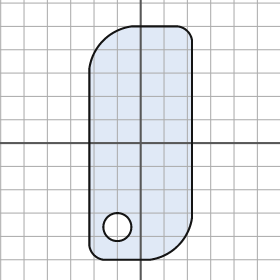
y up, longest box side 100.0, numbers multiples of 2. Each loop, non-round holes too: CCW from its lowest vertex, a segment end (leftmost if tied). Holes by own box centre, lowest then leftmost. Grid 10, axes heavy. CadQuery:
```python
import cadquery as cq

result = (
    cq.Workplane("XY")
    .moveTo(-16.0, -50.0)
    .lineTo(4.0, -50.0)
    .threePointArc((16.0, -44.0), (22.0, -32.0))
    .lineTo(22.0, 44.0)
    .threePointArc((20.0, 48.0), (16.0, 50.0))
    .lineTo(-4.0, 50.0)
    .threePointArc((-16.0, 44.0), (-22.0, 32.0))
    .lineTo(-22.0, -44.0)
    .threePointArc((-20.0, -48.0), (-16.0, -50.0))
    .close()
    .moveTo(-10.0, -36.0)
    .circle(6.0)
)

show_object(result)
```